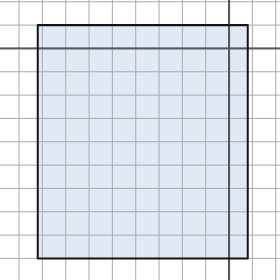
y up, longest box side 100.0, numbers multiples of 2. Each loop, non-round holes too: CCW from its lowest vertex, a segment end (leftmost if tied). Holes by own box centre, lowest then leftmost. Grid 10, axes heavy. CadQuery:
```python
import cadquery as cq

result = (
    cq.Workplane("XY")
    .moveTo(-82.0, -90.0)
    .lineTo(8.0, -90.0)
    .lineTo(8.0, 10.0)
    .lineTo(-82.0, 10.0)
    .close()
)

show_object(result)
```